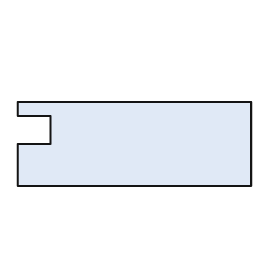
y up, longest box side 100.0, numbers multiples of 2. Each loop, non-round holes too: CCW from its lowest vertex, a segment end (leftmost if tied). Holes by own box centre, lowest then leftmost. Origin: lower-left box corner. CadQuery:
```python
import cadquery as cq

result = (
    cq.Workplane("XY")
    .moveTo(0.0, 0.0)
    .lineTo(100.0, 0.0)
    .lineTo(100.0, 36.0)
    .lineTo(0.0, 36.0)
    .lineTo(0.0, 30.0)
    .lineTo(14.0, 30.0)
    .lineTo(14.0, 18.0)
    .lineTo(0.0, 18.0)
    .close()
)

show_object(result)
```